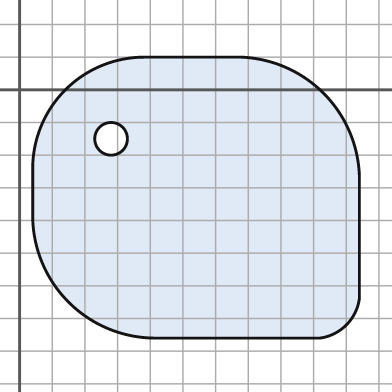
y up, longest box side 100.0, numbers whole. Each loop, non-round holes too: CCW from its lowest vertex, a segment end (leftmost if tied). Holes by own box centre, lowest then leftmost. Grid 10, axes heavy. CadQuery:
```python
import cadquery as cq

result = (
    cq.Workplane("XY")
    .moveTo(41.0, -76.0)
    .lineTo(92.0, -76.0)
    .threePointArc((100.0, -72.0), (104.0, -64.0))
    .lineTo(104.0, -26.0)
    .threePointArc((93.0, -1.0), (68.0, 10.0))
    .lineTo(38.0, 10.0)
    .threePointArc((14.0, 0.0), (4.0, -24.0))
    .lineTo(4.0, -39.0)
    .threePointArc((15.0, -65.0), (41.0, -76.0))
    .close()
    .moveTo(28.0, -15.0)
    .circle(5.0)
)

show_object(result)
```